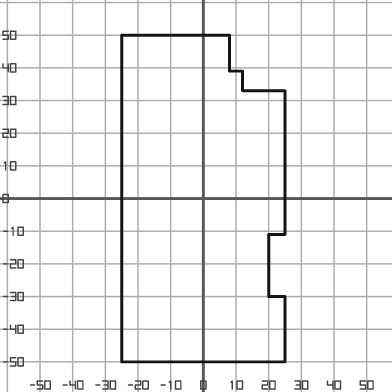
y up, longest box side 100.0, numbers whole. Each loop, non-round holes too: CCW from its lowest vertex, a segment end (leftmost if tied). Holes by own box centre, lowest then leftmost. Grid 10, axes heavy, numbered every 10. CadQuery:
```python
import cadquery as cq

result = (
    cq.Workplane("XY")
    .moveTo(-25.0, -50.0)
    .lineTo(25.0, -50.0)
    .lineTo(25.0, -30.0)
    .lineTo(20.0, -30.0)
    .lineTo(20.0, -11.0)
    .lineTo(25.0, -11.0)
    .lineTo(25.0, 33.0)
    .lineTo(12.0, 33.0)
    .lineTo(12.0, 39.0)
    .lineTo(8.0, 39.0)
    .lineTo(8.0, 50.0)
    .lineTo(-25.0, 50.0)
    .close()
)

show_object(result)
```